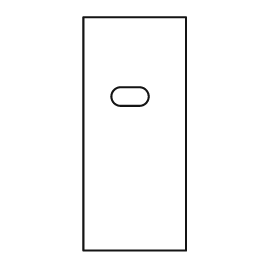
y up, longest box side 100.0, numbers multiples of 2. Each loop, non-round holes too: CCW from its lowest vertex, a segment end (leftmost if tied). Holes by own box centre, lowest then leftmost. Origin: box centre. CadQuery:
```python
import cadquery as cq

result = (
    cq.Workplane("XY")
    .moveTo(-22.0, -50.0)
    .lineTo(22.0, -50.0)
    .lineTo(22.0, 50.0)
    .lineTo(-22.0, 50.0)
    .close()
    .moveTo(-6.0, 12.0)
    .lineTo(2.0, 12.0)
    .threePointArc((6.0, 16.0), (2.0, 20.0))
    .lineTo(-6.0, 20.0)
    .threePointArc((-10.0, 16.0), (-6.0, 12.0))
    .close()
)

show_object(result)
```